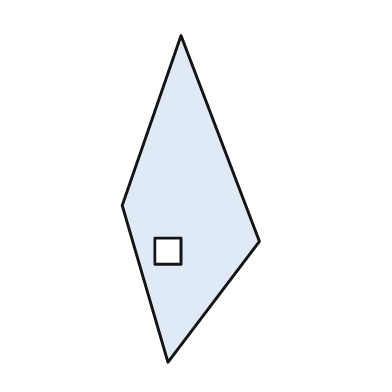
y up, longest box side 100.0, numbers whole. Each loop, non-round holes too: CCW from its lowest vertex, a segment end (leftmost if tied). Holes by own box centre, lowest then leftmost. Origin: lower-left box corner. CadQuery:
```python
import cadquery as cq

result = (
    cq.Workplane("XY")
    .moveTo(14.0, 0.0)
    .lineTo(42.0, 37.0)
    .lineTo(18.0, 100.0)
    .lineTo(0.0, 48.0)
    .close()
    .moveTo(10.0, 30.0)
    .lineTo(18.0, 30.0)
    .lineTo(18.0, 38.0)
    .lineTo(10.0, 38.0)
    .close()
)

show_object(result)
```